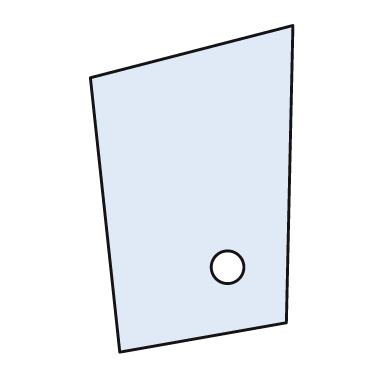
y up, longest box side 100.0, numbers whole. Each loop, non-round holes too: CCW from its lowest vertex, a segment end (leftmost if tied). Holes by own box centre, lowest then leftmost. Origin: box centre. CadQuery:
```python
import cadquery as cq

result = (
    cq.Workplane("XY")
    .moveTo(-22.0, -50.0)
    .lineTo(29.0, -41.0)
    .lineTo(31.0, 50.0)
    .lineTo(-31.0, 34.0)
    .close()
    .moveTo(11.0, -24.0)
    .circle(5.0)
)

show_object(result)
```